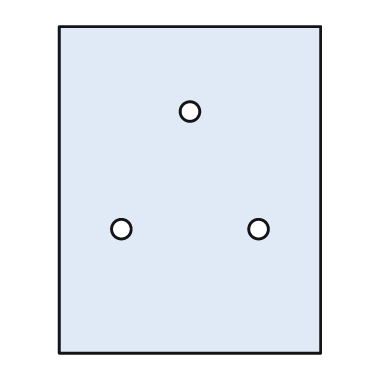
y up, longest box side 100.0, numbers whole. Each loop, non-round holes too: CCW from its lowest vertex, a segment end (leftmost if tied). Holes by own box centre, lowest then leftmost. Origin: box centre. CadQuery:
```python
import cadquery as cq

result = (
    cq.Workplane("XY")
    .moveTo(-40.0, -50.0)
    .lineTo(40.0, -50.0)
    .lineTo(40.0, 50.0)
    .lineTo(-40.0, 50.0)
    .close()
    .moveTo(-21.0, -12.0)
    .circle(3.0)
    .moveTo(21.0, -12.0)
    .circle(3.0)
    .moveTo(0.0, 24.0)
    .circle(3.0)
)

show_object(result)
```